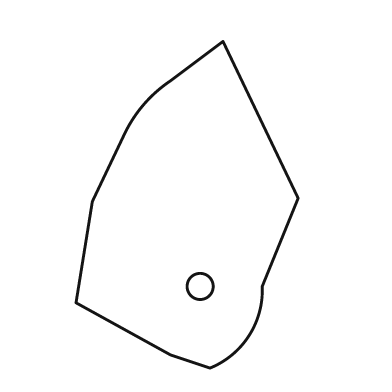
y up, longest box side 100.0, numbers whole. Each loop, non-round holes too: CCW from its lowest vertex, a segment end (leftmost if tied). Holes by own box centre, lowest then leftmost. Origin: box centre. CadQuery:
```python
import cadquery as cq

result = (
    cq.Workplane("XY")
    .moveTo(7.0, -50.0)
    .threePointArc((19.0, -40.0), (23.0, -25.0))
    .lineTo(34.0, 2.0)
    .lineTo(11.0, 50.0)
    .lineTo(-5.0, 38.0)
    .threePointArc((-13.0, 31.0), (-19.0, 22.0))
    .lineTo(-29.0, 1.0)
    .lineTo(-34.0, -30.0)
    .lineTo(-5.0, -46.0)
    .close()
    .moveTo(4.0, -25.0)
    .circle(4.0)
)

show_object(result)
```